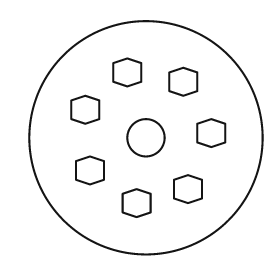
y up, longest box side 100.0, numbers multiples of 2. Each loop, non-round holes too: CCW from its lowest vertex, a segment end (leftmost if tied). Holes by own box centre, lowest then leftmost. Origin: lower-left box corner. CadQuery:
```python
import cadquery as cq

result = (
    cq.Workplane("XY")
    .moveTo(50.0, 50.0)
    .circle(50.0)
    .moveTo(46.0, 16.0)
    .lineTo(52.0, 18.0)
    .lineTo(52.0, 26.0)
    .lineTo(46.0, 28.0)
    .lineTo(40.0, 26.0)
    .lineTo(40.0, 18.0)
    .close()
    .moveTo(68.0, 22.0)
    .lineTo(74.0, 24.0)
    .lineTo(74.0, 32.0)
    .lineTo(68.0, 34.0)
    .lineTo(62.0, 32.0)
    .lineTo(62.0, 24.0)
    .close()
    .moveTo(26.0, 30.0)
    .lineTo(32.0, 32.0)
    .lineTo(32.0, 40.0)
    .lineTo(26.0, 42.0)
    .lineTo(20.0, 40.0)
    .lineTo(20.0, 32.0)
    .close()
    .moveTo(50.0, 50.0)
    .circle(8.0)
    .moveTo(78.0, 46.0)
    .lineTo(84.0, 48.0)
    .lineTo(84.0, 56.0)
    .lineTo(78.0, 58.0)
    .lineTo(72.0, 56.0)
    .lineTo(72.0, 48.0)
    .close()
    .moveTo(24.0, 56.0)
    .lineTo(30.0, 58.0)
    .lineTo(30.0, 66.0)
    .lineTo(24.0, 68.0)
    .lineTo(18.0, 66.0)
    .lineTo(18.0, 58.0)
    .close()
    .moveTo(66.0, 68.0)
    .lineTo(72.0, 70.0)
    .lineTo(72.0, 78.0)
    .lineTo(66.0, 80.0)
    .lineTo(60.0, 78.0)
    .lineTo(60.0, 70.0)
    .close()
    .moveTo(42.0, 72.0)
    .lineTo(48.0, 74.0)
    .lineTo(48.0, 82.0)
    .lineTo(42.0, 84.0)
    .lineTo(36.0, 82.0)
    .lineTo(36.0, 74.0)
    .close()
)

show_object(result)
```